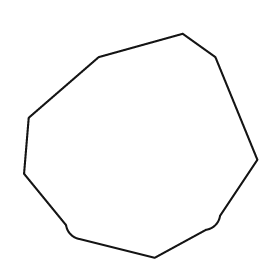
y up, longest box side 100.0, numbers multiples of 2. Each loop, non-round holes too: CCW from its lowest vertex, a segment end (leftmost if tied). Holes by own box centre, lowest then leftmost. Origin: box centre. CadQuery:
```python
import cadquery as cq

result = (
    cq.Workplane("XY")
    .moveTo(6.0, -48.0)
    .lineTo(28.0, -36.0)
    .threePointArc((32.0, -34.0), (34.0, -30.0))
    .lineTo(50.0, -6.0)
    .lineTo(32.0, 38.0)
    .lineTo(18.0, 48.0)
    .lineTo(-18.0, 38.0)
    .lineTo(-48.0, 12.0)
    .lineTo(-50.0, -12.0)
    .lineTo(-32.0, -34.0)
    .threePointArc((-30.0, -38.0), (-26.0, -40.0))
    .close()
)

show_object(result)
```